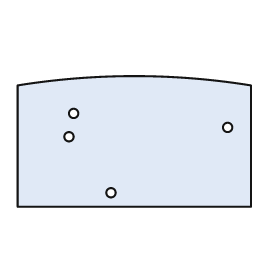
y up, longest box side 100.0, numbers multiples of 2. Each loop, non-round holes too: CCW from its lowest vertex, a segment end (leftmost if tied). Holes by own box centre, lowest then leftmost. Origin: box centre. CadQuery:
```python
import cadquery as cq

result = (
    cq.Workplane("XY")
    .moveTo(-50.0, -28.0)
    .lineTo(50.0, -28.0)
    .lineTo(50.0, 24.0)
    .threePointArc((0.0, 28.0), (-50.0, 24.0))
    .close()
    .moveTo(-10.0, -22.0)
    .circle(2.0)
    .moveTo(-28.0, 2.0)
    .circle(2.0)
    .moveTo(40.0, 6.0)
    .circle(2.0)
    .moveTo(-26.0, 12.0)
    .circle(2.0)
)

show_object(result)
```